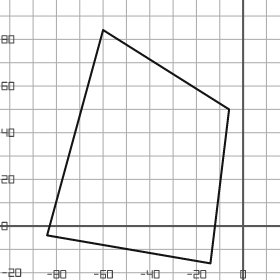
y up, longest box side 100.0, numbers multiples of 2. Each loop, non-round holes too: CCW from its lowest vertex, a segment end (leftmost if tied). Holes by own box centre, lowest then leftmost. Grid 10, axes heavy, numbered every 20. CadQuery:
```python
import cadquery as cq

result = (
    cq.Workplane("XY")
    .moveTo(-14.0, -16.0)
    .lineTo(-6.0, 50.0)
    .lineTo(-60.0, 84.0)
    .lineTo(-84.0, -4.0)
    .close()
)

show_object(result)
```